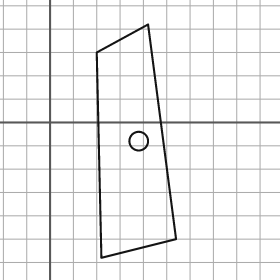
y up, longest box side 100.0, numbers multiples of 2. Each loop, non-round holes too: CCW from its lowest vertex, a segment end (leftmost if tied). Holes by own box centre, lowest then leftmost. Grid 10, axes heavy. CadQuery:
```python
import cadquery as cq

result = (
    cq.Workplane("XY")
    .moveTo(22.0, -58.0)
    .lineTo(54.0, -50.0)
    .lineTo(42.0, 42.0)
    .lineTo(20.0, 30.0)
    .close()
    .moveTo(38.0, -8.0)
    .circle(4.0)
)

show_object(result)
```